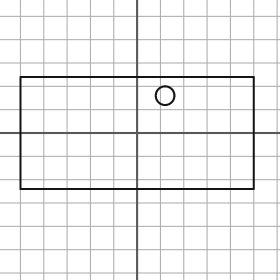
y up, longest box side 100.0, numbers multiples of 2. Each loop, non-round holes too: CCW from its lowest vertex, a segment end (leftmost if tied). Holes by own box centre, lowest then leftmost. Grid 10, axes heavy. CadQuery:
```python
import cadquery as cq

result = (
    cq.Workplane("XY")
    .moveTo(-50.0, -24.0)
    .lineTo(50.0, -24.0)
    .lineTo(50.0, 24.0)
    .lineTo(-50.0, 24.0)
    .close()
    .moveTo(12.0, 16.0)
    .circle(4.0)
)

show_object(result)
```